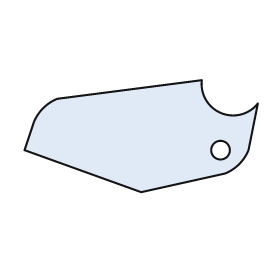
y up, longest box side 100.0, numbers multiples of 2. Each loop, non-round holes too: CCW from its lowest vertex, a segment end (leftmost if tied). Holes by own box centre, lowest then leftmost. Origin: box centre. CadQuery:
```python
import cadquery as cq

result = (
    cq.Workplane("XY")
    .moveTo(0.0, -24.0)
    .lineTo(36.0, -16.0)
    .threePointArc((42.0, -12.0), (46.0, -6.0))
    .lineTo(50.0, 14.0)
    .threePointArc((34.0, 10.0), (26.0, 24.0))
    .lineTo(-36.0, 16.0)
    .threePointArc((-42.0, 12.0), (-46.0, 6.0))
    .lineTo(-50.0, -6.0)
    .close()
    .moveTo(34.0, -6.0)
    .circle(4.0)
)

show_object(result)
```